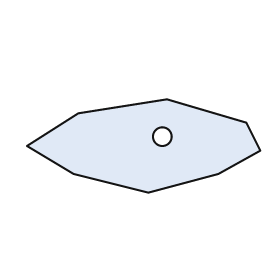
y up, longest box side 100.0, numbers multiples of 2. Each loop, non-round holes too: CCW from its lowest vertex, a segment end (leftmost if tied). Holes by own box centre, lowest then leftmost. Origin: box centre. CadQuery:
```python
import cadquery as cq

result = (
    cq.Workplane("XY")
    .moveTo(2.0, -20.0)
    .lineTo(32.0, -12.0)
    .lineTo(50.0, -2.0)
    .lineTo(44.0, 10.0)
    .lineTo(10.0, 20.0)
    .lineTo(-28.0, 14.0)
    .lineTo(-50.0, 0.0)
    .lineTo(-30.0, -12.0)
    .close()
    .moveTo(8.0, 4.0)
    .circle(4.0)
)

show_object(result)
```